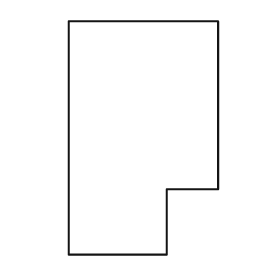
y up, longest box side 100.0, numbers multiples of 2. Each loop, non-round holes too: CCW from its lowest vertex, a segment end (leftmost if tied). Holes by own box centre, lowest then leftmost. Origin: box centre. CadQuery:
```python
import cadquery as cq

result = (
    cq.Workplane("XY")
    .moveTo(-32.0, -50.0)
    .lineTo(10.0, -50.0)
    .lineTo(10.0, -22.0)
    .lineTo(32.0, -22.0)
    .lineTo(32.0, 50.0)
    .lineTo(-32.0, 50.0)
    .close()
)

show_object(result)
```